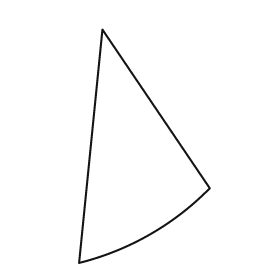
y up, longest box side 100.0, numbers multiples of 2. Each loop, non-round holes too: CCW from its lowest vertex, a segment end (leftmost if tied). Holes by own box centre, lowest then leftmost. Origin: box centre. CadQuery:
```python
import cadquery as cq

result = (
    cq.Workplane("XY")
    .moveTo(-28.0, -50.0)
    .threePointArc((2.0, -38.0), (28.0, -18.0))
    .lineTo(-18.0, 50.0)
    .close()
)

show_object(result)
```